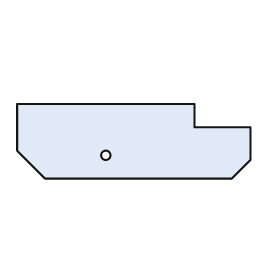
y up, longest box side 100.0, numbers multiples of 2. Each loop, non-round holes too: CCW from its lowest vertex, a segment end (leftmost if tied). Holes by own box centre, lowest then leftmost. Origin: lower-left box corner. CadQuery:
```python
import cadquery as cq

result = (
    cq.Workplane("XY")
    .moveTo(12.0, 0.0)
    .lineTo(92.0, 0.0)
    .lineTo(100.0, 8.0)
    .lineTo(100.0, 22.0)
    .lineTo(76.0, 22.0)
    .lineTo(76.0, 32.0)
    .lineTo(0.0, 32.0)
    .lineTo(0.0, 12.0)
    .close()
    .moveTo(38.0, 10.0)
    .circle(2.0)
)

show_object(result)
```